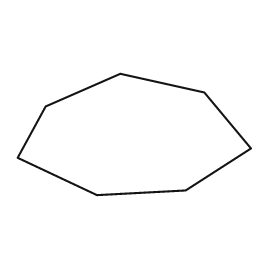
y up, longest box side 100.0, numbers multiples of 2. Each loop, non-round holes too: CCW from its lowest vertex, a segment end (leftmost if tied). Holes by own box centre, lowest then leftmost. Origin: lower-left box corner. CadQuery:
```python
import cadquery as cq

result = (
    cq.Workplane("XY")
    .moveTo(34.0, 0.0)
    .lineTo(72.0, 2.0)
    .lineTo(100.0, 20.0)
    .lineTo(80.0, 44.0)
    .lineTo(44.0, 52.0)
    .lineTo(12.0, 38.0)
    .lineTo(0.0, 16.0)
    .close()
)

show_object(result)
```